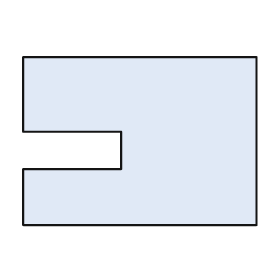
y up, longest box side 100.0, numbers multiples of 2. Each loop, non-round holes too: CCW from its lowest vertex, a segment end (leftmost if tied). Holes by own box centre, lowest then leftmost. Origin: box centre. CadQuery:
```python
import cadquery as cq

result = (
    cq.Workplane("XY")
    .moveTo(-50.0, -36.0)
    .lineTo(50.0, -36.0)
    .lineTo(50.0, 36.0)
    .lineTo(-50.0, 36.0)
    .lineTo(-50.0, 4.0)
    .lineTo(-8.0, 4.0)
    .lineTo(-8.0, -12.0)
    .lineTo(-50.0, -12.0)
    .close()
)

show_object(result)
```